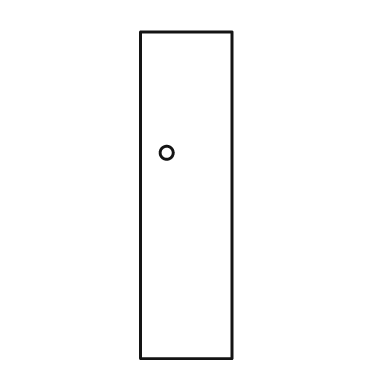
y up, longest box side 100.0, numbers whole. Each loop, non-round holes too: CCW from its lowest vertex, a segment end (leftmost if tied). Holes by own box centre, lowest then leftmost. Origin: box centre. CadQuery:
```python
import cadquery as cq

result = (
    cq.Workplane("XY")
    .moveTo(-14.0, -50.0)
    .lineTo(14.0, -50.0)
    .lineTo(14.0, 50.0)
    .lineTo(-14.0, 50.0)
    .close()
    .moveTo(-6.0, 13.0)
    .circle(2.0)
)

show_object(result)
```